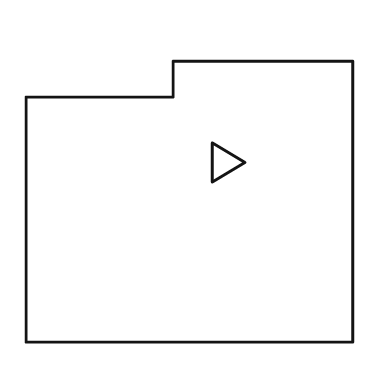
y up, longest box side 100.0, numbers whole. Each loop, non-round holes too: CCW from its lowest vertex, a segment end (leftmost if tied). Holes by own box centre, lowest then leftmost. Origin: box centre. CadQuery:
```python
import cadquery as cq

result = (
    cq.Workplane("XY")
    .moveTo(-50.0, -43.0)
    .lineTo(50.0, -43.0)
    .lineTo(50.0, 43.0)
    .lineTo(-5.0, 43.0)
    .lineTo(-5.0, 32.0)
    .lineTo(-50.0, 32.0)
    .close()
    .moveTo(7.0, 6.0)
    .lineTo(17.0, 12.0)
    .lineTo(7.0, 18.0)
    .close()
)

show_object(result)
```